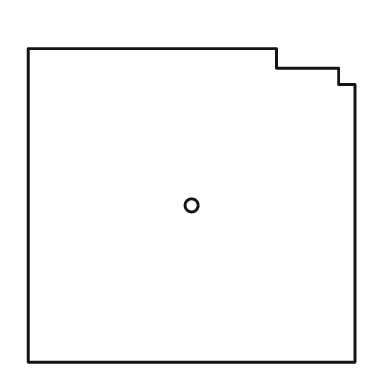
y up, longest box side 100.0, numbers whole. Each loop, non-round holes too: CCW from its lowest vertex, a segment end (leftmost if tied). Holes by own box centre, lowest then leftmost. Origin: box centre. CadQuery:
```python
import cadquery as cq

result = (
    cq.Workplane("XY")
    .moveTo(-50.0, -48.0)
    .lineTo(50.0, -48.0)
    .lineTo(50.0, 37.0)
    .lineTo(45.0, 37.0)
    .lineTo(45.0, 42.0)
    .lineTo(26.0, 42.0)
    .lineTo(26.0, 48.0)
    .lineTo(-50.0, 48.0)
    .close()
    .moveTo(0.0, 0.0)
    .circle(2.0)
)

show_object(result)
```